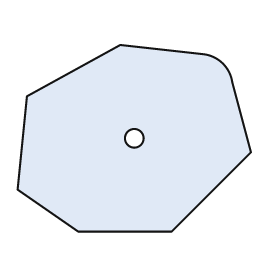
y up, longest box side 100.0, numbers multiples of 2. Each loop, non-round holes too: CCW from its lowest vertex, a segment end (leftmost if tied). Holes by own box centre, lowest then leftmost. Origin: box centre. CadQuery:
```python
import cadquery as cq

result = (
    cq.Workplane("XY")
    .moveTo(-24.0, -40.0)
    .lineTo(16.0, -40.0)
    .lineTo(50.0, -6.0)
    .lineTo(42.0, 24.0)
    .threePointArc((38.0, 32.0), (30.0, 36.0))
    .lineTo(-6.0, 40.0)
    .lineTo(-46.0, 18.0)
    .lineTo(-50.0, -22.0)
    .close()
    .moveTo(0.0, 0.0)
    .circle(4.0)
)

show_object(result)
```